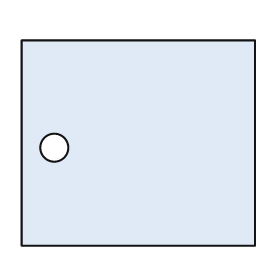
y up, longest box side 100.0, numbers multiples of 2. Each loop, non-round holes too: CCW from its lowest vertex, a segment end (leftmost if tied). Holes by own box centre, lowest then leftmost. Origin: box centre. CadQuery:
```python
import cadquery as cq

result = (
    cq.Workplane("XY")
    .moveTo(-50.0, -44.0)
    .lineTo(50.0, -44.0)
    .lineTo(50.0, 44.0)
    .lineTo(-50.0, 44.0)
    .close()
    .moveTo(-36.0, -2.0)
    .circle(6.0)
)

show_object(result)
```